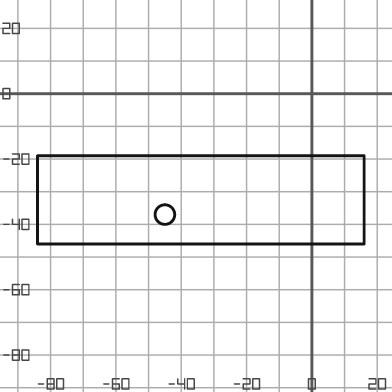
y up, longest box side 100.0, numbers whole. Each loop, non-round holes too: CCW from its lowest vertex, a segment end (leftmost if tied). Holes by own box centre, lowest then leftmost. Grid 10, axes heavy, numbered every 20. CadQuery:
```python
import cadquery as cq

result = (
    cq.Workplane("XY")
    .moveTo(-84.0, -46.0)
    .lineTo(16.0, -46.0)
    .lineTo(16.0, -19.0)
    .lineTo(-84.0, -19.0)
    .close()
    .moveTo(-45.0, -37.0)
    .circle(3.0)
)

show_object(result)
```